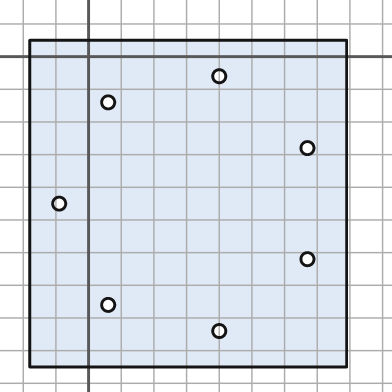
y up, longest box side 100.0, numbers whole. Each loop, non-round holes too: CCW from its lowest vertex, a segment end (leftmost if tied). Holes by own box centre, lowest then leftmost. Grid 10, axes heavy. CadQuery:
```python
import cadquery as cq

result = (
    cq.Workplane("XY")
    .moveTo(-18.0, -95.0)
    .lineTo(79.0, -95.0)
    .lineTo(79.0, 5.0)
    .lineTo(-18.0, 5.0)
    .close()
    .moveTo(40.0, -84.0)
    .circle(2.0)
    .moveTo(6.0, -76.0)
    .circle(2.0)
    .moveTo(67.0, -62.0)
    .circle(2.0)
    .moveTo(-9.0, -45.0)
    .circle(2.0)
    .moveTo(67.0, -28.0)
    .circle(2.0)
    .moveTo(6.0, -14.0)
    .circle(2.0)
    .moveTo(40.0, -6.0)
    .circle(2.0)
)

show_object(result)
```